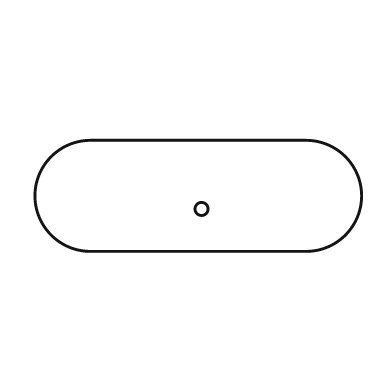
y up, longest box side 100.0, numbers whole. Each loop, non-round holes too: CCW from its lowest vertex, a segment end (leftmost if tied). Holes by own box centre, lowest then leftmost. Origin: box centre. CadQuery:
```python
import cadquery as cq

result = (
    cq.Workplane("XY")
    .moveTo(-33.0, -17.0)
    .lineTo(33.0, -17.0)
    .threePointArc((50.0, 0.0), (33.0, 17.0))
    .lineTo(-33.0, 17.0)
    .threePointArc((-50.0, 0.0), (-33.0, -17.0))
    .close()
    .moveTo(1.0, -4.0)
    .circle(2.0)
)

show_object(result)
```